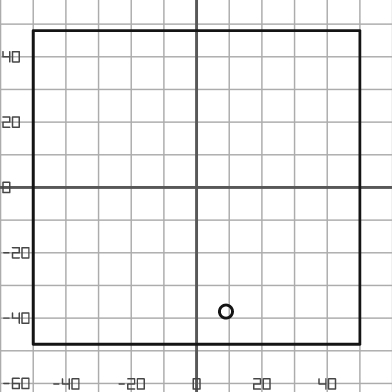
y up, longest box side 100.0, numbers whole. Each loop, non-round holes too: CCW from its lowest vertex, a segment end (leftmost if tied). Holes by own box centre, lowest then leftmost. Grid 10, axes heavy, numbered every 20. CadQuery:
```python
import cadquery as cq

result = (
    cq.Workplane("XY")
    .moveTo(-50.0, -48.0)
    .lineTo(50.0, -48.0)
    .lineTo(50.0, 48.0)
    .lineTo(-50.0, 48.0)
    .close()
    .moveTo(9.0, -38.0)
    .circle(2.0)
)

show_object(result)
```